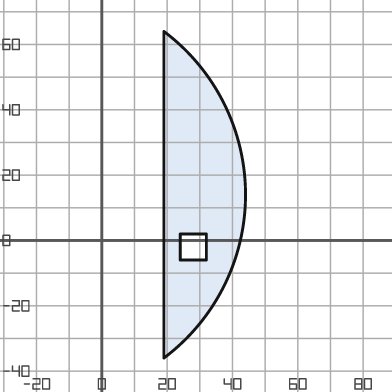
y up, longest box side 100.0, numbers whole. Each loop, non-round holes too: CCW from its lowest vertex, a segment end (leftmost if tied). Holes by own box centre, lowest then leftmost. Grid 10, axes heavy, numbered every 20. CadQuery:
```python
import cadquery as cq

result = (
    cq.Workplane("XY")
    .moveTo(19.0, -36.0)
    .threePointArc((44.0, 14.0), (19.0, 64.0))
    .close()
    .moveTo(24.0, -6.0)
    .lineTo(32.0, -6.0)
    .lineTo(32.0, 2.0)
    .lineTo(24.0, 2.0)
    .close()
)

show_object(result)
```